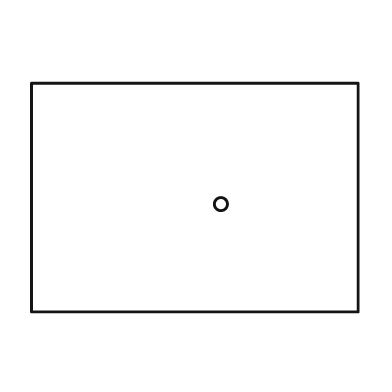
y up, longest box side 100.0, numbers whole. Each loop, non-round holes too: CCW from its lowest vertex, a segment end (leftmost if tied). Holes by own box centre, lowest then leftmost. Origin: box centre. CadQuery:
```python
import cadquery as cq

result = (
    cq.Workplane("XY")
    .moveTo(-50.0, -35.0)
    .lineTo(50.0, -35.0)
    .lineTo(50.0, 35.0)
    .lineTo(-50.0, 35.0)
    .close()
    .moveTo(8.0, -2.0)
    .circle(2.0)
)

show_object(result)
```